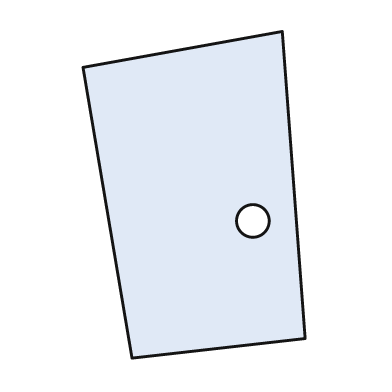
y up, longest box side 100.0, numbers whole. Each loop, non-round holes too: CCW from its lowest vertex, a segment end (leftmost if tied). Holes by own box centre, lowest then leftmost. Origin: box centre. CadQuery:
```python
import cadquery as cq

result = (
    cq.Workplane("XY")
    .moveTo(-19.0, -50.0)
    .lineTo(34.0, -44.0)
    .lineTo(27.0, 50.0)
    .lineTo(-34.0, 39.0)
    .close()
    .moveTo(18.0, -8.0)
    .circle(5.0)
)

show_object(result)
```